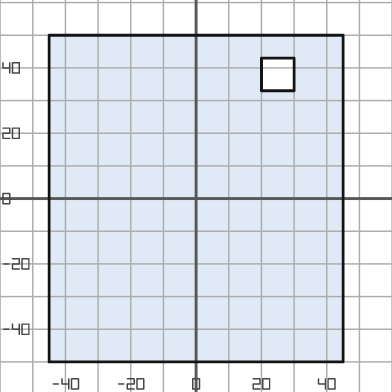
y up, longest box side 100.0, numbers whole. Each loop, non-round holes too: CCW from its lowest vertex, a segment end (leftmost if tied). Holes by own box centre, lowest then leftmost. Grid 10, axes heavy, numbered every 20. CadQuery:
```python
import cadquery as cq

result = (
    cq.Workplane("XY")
    .moveTo(-45.0, -50.0)
    .lineTo(45.0, -50.0)
    .lineTo(45.0, 50.0)
    .lineTo(-45.0, 50.0)
    .close()
    .moveTo(20.0, 33.0)
    .lineTo(30.0, 33.0)
    .lineTo(30.0, 43.0)
    .lineTo(20.0, 43.0)
    .close()
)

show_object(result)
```